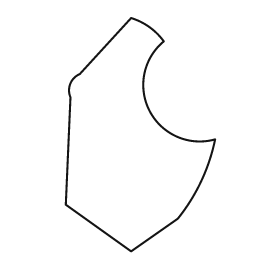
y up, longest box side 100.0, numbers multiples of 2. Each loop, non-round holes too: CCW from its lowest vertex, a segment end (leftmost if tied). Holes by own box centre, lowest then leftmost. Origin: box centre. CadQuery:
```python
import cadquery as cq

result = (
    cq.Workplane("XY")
    .moveTo(-4.0, -50.0)
    .lineTo(16.0, -36.0)
    .threePointArc((26.0, -20.0), (32.0, -2.0))
    .threePointArc((4.0, 10.0), (10.0, 40.0))
    .threePointArc((4.0, 46.0), (-4.0, 50.0))
    .lineTo(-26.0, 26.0)
    .threePointArc((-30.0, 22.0), (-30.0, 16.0))
    .lineTo(-32.0, -30.0)
    .close()
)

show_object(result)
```